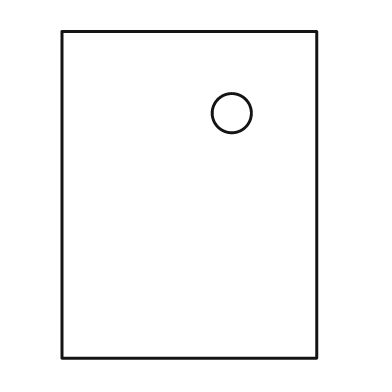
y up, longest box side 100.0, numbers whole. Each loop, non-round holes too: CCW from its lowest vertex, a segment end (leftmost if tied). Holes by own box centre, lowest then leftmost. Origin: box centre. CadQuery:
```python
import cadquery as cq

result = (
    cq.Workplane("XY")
    .moveTo(-39.0, -50.0)
    .lineTo(39.0, -50.0)
    .lineTo(39.0, 50.0)
    .lineTo(-39.0, 50.0)
    .close()
    .moveTo(13.0, 25.0)
    .circle(6.0)
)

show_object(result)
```